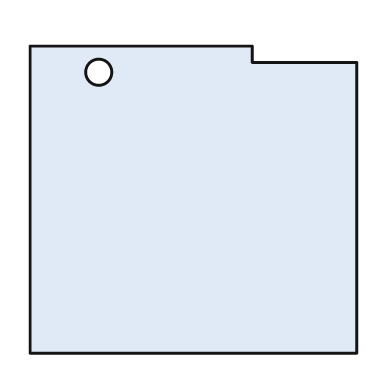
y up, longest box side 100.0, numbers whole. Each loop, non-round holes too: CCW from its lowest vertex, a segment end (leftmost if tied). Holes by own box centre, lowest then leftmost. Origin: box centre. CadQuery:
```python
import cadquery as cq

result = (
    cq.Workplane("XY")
    .moveTo(-50.0, -47.0)
    .lineTo(50.0, -47.0)
    .lineTo(50.0, 42.0)
    .lineTo(18.0, 42.0)
    .lineTo(18.0, 47.0)
    .lineTo(-50.0, 47.0)
    .close()
    .moveTo(-29.0, 39.0)
    .circle(4.0)
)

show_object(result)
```